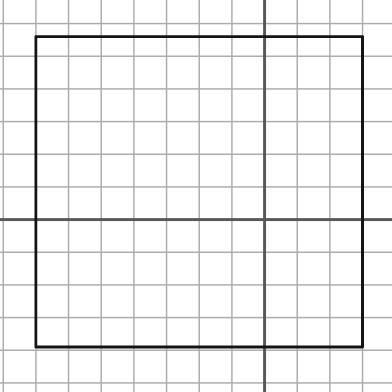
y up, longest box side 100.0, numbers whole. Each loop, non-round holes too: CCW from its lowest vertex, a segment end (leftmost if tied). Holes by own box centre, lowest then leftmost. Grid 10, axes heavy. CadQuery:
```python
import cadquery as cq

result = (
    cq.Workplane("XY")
    .moveTo(-70.0, -39.0)
    .lineTo(30.0, -39.0)
    .lineTo(30.0, 56.0)
    .lineTo(-70.0, 56.0)
    .close()
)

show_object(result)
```